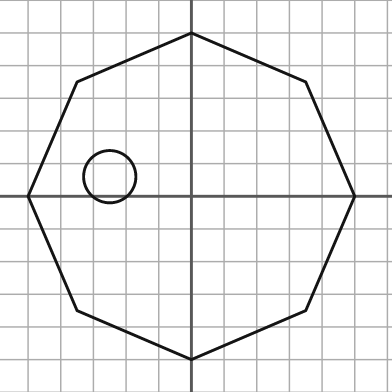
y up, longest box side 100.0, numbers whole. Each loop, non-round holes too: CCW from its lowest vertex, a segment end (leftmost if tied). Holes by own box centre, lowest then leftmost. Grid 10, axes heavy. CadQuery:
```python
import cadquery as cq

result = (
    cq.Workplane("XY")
    .moveTo(0.0, -50.0)
    .lineTo(35.0, -35.0)
    .lineTo(50.0, 0.0)
    .lineTo(35.0, 35.0)
    .lineTo(0.0, 50.0)
    .lineTo(-35.0, 35.0)
    .lineTo(-50.0, 0.0)
    .lineTo(-35.0, -35.0)
    .close()
    .moveTo(-25.0, 6.0)
    .circle(8.0)
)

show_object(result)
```